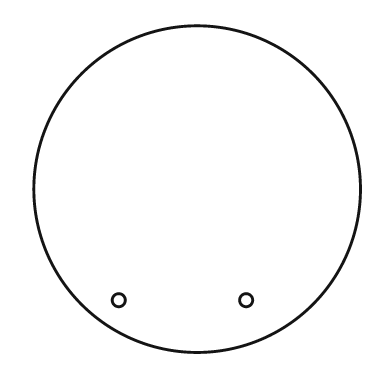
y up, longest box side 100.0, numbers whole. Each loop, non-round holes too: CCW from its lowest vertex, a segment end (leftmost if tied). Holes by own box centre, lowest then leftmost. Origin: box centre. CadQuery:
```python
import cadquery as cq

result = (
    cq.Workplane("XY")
    .moveTo(0.0, 0.0)
    .circle(50.0)
    .moveTo(-24.0, -34.0)
    .circle(2.0)
    .moveTo(15.0, -34.0)
    .circle(2.0)
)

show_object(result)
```